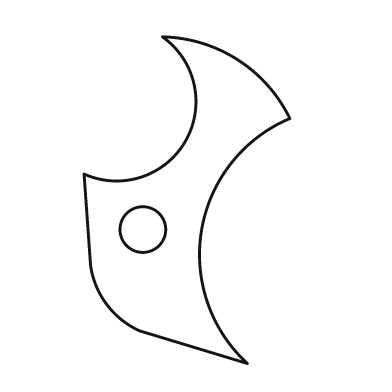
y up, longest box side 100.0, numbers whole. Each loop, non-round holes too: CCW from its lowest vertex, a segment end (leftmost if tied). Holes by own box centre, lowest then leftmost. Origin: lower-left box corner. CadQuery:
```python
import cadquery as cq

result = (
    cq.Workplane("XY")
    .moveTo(50.0, 0.0)
    .threePointArc((36.0, 41.0), (63.0, 75.0))
    .threePointArc((47.0, 93.0), (24.0, 100.0))
    .threePointArc((31.0, 68.0), (0.0, 58.0))
    .lineTo(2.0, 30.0)
    .threePointArc((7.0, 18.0), (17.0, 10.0))
    .close()
    .moveTo(18.0, 41.0)
    .circle(7.0)
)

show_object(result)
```